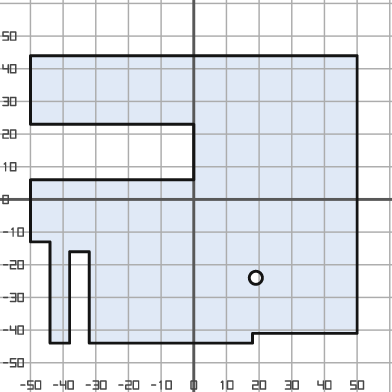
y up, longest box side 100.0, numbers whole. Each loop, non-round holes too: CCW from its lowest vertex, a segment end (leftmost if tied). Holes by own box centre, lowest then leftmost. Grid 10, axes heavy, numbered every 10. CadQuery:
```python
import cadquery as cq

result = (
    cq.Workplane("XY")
    .moveTo(-44.0, -44.0)
    .lineTo(-38.0, -44.0)
    .lineTo(-38.0, -16.0)
    .lineTo(-32.0, -16.0)
    .lineTo(-32.0, -44.0)
    .lineTo(18.0, -44.0)
    .lineTo(18.0, -41.0)
    .lineTo(50.0, -41.0)
    .lineTo(50.0, 44.0)
    .lineTo(-50.0, 44.0)
    .lineTo(-50.0, 23.0)
    .lineTo(0.0, 23.0)
    .lineTo(0.0, 6.0)
    .lineTo(-50.0, 6.0)
    .lineTo(-50.0, -13.0)
    .lineTo(-44.0, -13.0)
    .close()
    .moveTo(19.0, -24.0)
    .circle(2.0)
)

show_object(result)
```